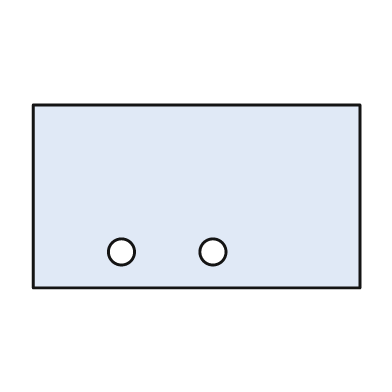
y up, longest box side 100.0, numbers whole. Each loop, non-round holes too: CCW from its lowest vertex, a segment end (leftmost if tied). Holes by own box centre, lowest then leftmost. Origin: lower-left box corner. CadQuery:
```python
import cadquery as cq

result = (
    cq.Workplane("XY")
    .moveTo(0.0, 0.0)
    .lineTo(100.0, 0.0)
    .lineTo(100.0, 56.0)
    .lineTo(0.0, 56.0)
    .close()
    .moveTo(27.0, 11.0)
    .circle(4.0)
    .moveTo(55.0, 11.0)
    .circle(4.0)
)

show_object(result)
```